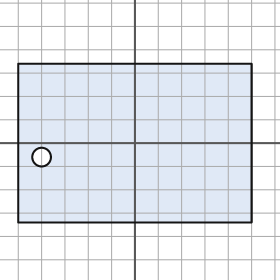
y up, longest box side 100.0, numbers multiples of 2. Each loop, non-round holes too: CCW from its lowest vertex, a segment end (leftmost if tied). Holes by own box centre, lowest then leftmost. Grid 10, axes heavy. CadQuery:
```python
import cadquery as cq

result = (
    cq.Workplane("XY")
    .moveTo(-50.0, -34.0)
    .lineTo(50.0, -34.0)
    .lineTo(50.0, 34.0)
    .lineTo(-50.0, 34.0)
    .close()
    .moveTo(-40.0, -6.0)
    .circle(4.0)
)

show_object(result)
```